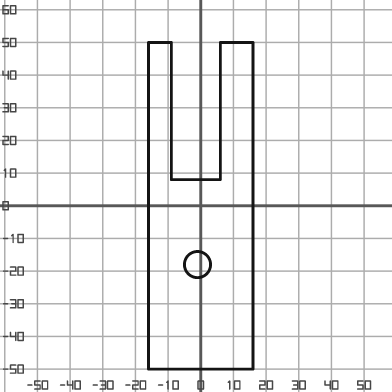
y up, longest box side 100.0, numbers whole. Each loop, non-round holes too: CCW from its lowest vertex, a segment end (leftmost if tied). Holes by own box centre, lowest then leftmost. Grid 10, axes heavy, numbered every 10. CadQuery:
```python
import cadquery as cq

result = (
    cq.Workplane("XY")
    .moveTo(-16.0, -50.0)
    .lineTo(16.0, -50.0)
    .lineTo(16.0, 50.0)
    .lineTo(6.0, 50.0)
    .lineTo(6.0, 8.0)
    .lineTo(-9.0, 8.0)
    .lineTo(-9.0, 50.0)
    .lineTo(-16.0, 50.0)
    .close()
    .moveTo(-1.0, -18.0)
    .circle(4.0)
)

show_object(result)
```